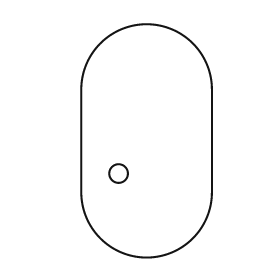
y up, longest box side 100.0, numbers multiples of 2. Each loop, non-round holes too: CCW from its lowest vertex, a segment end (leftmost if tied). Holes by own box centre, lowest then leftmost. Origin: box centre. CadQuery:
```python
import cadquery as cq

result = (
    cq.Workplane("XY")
    .moveTo(-28.0, -22.0)
    .threePointArc((0.0, -50.0), (28.0, -22.0))
    .lineTo(28.0, 22.0)
    .threePointArc((0.0, 50.0), (-28.0, 22.0))
    .close()
    .moveTo(-12.0, -14.0)
    .circle(4.0)
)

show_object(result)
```